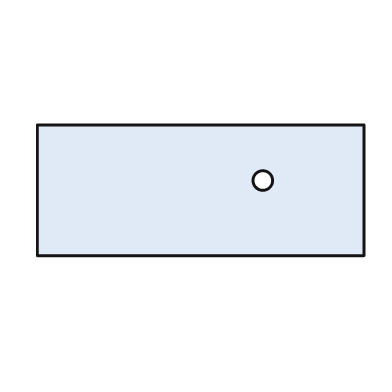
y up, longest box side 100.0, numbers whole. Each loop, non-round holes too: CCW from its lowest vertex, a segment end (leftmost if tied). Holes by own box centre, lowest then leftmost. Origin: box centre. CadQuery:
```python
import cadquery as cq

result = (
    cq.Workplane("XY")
    .moveTo(-50.0, -20.0)
    .lineTo(50.0, -20.0)
    .lineTo(50.0, 20.0)
    .lineTo(-50.0, 20.0)
    .close()
    .moveTo(19.0, 3.0)
    .circle(3.0)
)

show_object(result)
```